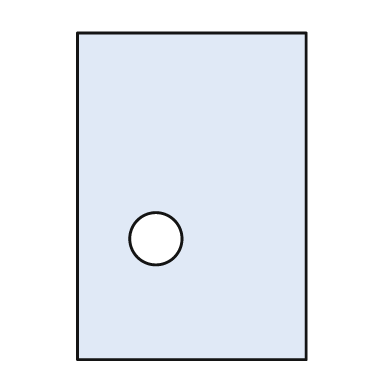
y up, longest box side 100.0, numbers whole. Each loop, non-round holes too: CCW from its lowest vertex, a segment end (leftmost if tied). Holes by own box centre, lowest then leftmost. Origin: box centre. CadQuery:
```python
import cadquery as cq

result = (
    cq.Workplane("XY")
    .moveTo(-35.0, -50.0)
    .lineTo(35.0, -50.0)
    .lineTo(35.0, 50.0)
    .lineTo(-35.0, 50.0)
    .close()
    .moveTo(-11.0, -13.0)
    .circle(8.0)
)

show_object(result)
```